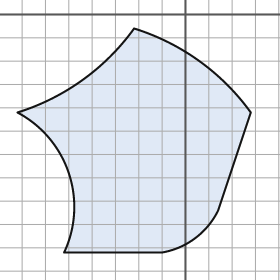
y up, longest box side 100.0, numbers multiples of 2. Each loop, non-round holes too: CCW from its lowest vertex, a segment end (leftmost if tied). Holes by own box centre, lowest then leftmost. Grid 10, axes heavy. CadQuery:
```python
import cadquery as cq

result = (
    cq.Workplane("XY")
    .moveTo(-52.0, -102.0)
    .lineTo(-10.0, -102.0)
    .threePointArc((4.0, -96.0), (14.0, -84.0))
    .lineTo(28.0, -42.0)
    .threePointArc((6.0, -20.0), (-22.0, -6.0))
    .threePointArc((-44.0, -28.0), (-72.0, -42.0))
    .threePointArc((-50.0, -68.0), (-52.0, -102.0))
    .close()
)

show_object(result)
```